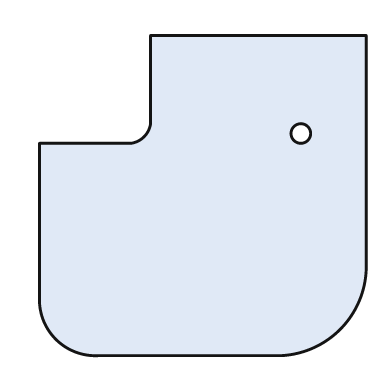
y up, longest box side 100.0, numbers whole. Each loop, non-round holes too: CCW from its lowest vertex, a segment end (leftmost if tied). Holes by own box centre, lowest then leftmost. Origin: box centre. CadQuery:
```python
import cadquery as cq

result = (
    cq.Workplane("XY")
    .moveTo(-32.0, -49.0)
    .lineTo(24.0, -49.0)
    .threePointArc((42.0, -41.0), (50.0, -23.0))
    .lineTo(50.0, 49.0)
    .lineTo(-16.0, 49.0)
    .lineTo(-16.0, 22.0)
    .threePointArc((-18.0, 18.0), (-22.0, 16.0))
    .lineTo(-50.0, 16.0)
    .lineTo(-50.0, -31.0)
    .threePointArc((-45.0, -44.0), (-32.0, -49.0))
    .close()
    .moveTo(30.0, 19.0)
    .circle(3.0)
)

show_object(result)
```